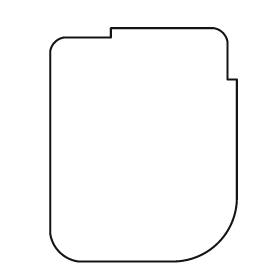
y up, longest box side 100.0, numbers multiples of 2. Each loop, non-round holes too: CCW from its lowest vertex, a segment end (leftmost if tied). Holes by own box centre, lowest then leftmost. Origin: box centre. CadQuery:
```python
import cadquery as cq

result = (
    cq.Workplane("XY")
    .moveTo(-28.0, -50.0)
    .lineTo(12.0, -50.0)
    .threePointArc((32.0, -42.0), (40.0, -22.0))
    .lineTo(40.0, 28.0)
    .lineTo(36.0, 28.0)
    .lineTo(36.0, 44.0)
    .threePointArc((34.0, 48.0), (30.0, 50.0))
    .lineTo(-14.0, 50.0)
    .lineTo(-14.0, 46.0)
    .lineTo(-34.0, 46.0)
    .threePointArc((-38.0, 44.0), (-40.0, 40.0))
    .lineTo(-40.0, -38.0)
    .threePointArc((-36.0, -46.0), (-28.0, -50.0))
    .close()
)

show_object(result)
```